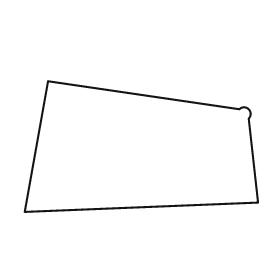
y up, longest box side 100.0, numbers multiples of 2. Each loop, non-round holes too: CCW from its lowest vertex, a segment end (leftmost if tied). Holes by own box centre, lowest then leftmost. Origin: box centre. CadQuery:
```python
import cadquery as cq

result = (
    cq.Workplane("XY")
    .moveTo(-50.0, -28.0)
    .lineTo(50.0, -24.0)
    .lineTo(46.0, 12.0)
    .threePointArc((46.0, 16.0), (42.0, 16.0))
    .lineTo(-40.0, 28.0)
    .close()
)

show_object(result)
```